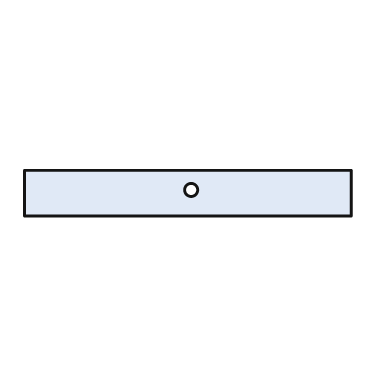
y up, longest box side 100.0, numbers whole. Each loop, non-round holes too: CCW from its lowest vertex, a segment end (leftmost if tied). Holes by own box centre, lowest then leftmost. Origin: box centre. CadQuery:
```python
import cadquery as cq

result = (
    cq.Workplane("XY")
    .moveTo(-50.0, -7.0)
    .lineTo(50.0, -7.0)
    .lineTo(50.0, 7.0)
    .lineTo(-50.0, 7.0)
    .close()
    .moveTo(1.0, 1.0)
    .circle(2.0)
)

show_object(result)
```